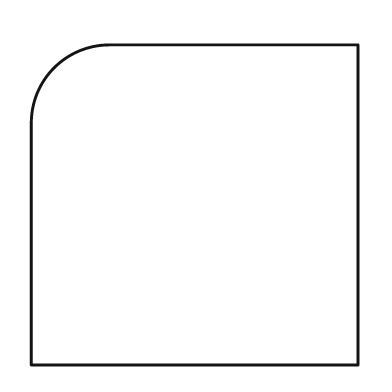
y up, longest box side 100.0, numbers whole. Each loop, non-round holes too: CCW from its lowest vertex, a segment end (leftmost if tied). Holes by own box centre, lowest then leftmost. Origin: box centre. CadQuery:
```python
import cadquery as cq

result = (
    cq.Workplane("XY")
    .moveTo(-50.0, -49.0)
    .lineTo(50.0, -49.0)
    .lineTo(50.0, 49.0)
    .lineTo(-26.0, 49.0)
    .threePointArc((-43.0, 42.0), (-50.0, 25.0))
    .close()
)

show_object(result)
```